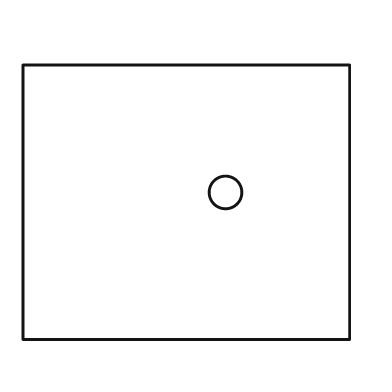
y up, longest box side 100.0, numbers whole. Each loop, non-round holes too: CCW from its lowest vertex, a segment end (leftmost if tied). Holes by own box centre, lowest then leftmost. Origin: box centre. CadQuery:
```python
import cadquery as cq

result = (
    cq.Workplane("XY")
    .moveTo(-50.0, -42.0)
    .lineTo(50.0, -42.0)
    .lineTo(50.0, 42.0)
    .lineTo(-50.0, 42.0)
    .close()
    .moveTo(12.0, 3.0)
    .circle(5.0)
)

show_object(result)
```